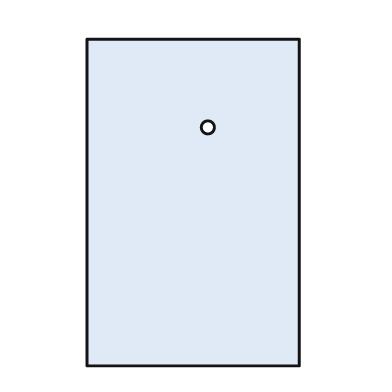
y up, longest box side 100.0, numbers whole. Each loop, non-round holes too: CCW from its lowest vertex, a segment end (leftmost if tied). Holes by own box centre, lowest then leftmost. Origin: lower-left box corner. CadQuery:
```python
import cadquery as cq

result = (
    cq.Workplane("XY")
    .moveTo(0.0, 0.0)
    .lineTo(65.0, 0.0)
    .lineTo(65.0, 100.0)
    .lineTo(0.0, 100.0)
    .close()
    .moveTo(37.0, 73.0)
    .circle(2.0)
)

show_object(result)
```